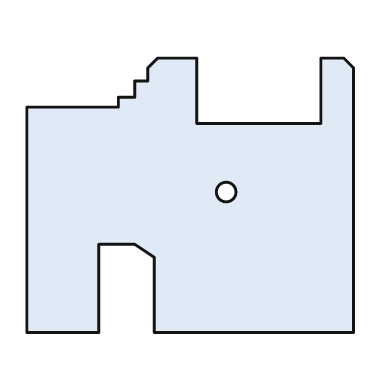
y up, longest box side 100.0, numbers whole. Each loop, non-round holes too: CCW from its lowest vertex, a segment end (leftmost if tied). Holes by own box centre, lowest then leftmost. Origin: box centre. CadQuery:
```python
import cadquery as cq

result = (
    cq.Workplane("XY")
    .moveTo(-50.0, -42.0)
    .lineTo(-28.0, -42.0)
    .lineTo(-28.0, -15.0)
    .lineTo(-17.0, -15.0)
    .lineTo(-11.0, -19.0)
    .lineTo(-11.0, -42.0)
    .lineTo(50.0, -42.0)
    .lineTo(50.0, 39.0)
    .lineTo(47.0, 42.0)
    .lineTo(40.0, 42.0)
    .lineTo(40.0, 22.0)
    .lineTo(2.0, 22.0)
    .lineTo(2.0, 42.0)
    .lineTo(-10.0, 42.0)
    .lineTo(-13.0, 39.0)
    .lineTo(-13.0, 35.0)
    .lineTo(-17.0, 35.0)
    .lineTo(-17.0, 30.0)
    .lineTo(-22.0, 30.0)
    .lineTo(-22.0, 27.0)
    .lineTo(-50.0, 27.0)
    .close()
    .moveTo(11.0, 1.0)
    .circle(3.0)
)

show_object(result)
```